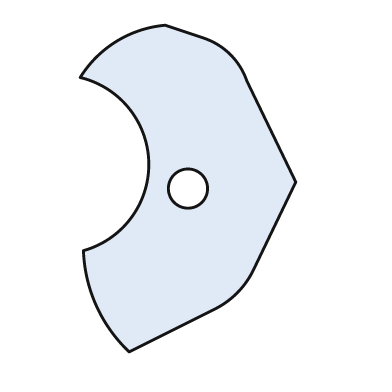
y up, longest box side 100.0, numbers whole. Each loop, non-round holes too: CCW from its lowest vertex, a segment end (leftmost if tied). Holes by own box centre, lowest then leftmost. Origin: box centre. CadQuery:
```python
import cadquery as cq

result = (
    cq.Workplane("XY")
    .moveTo(-18.0, -50.0)
    .lineTo(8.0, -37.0)
    .threePointArc((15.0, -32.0), (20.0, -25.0))
    .lineTo(33.0, 2.0)
    .lineTo(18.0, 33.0)
    .threePointArc((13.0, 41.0), (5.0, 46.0))
    .lineTo(-7.0, 50.0)
    .threePointArc((-22.0, 45.0), (-33.0, 34.0))
    .threePointArc((-12.0, 8.0), (-32.0, -19.0))
    .threePointArc((-28.0, -36.0), (-18.0, -50.0))
    .close()
    .moveTo(0.0, 0.0)
    .circle(6.0)
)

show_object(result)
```